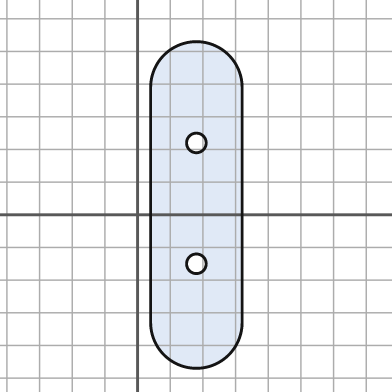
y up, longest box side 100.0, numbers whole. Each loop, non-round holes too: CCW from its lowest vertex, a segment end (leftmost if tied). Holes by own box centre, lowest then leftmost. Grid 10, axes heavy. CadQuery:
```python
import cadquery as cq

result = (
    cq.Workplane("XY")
    .moveTo(4.0, -33.0)
    .threePointArc((18.0, -47.0), (32.0, -33.0))
    .lineTo(32.0, 39.0)
    .threePointArc((18.0, 53.0), (4.0, 39.0))
    .close()
    .moveTo(18.0, -15.0)
    .circle(3.0)
    .moveTo(18.0, 22.0)
    .circle(3.0)
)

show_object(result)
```